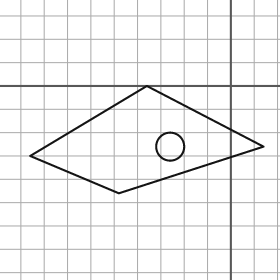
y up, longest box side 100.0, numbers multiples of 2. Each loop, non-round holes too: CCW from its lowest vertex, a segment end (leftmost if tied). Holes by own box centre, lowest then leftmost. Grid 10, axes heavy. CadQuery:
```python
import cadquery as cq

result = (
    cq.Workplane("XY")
    .moveTo(-48.0, -46.0)
    .lineTo(14.0, -26.0)
    .lineTo(-36.0, 0.0)
    .lineTo(-86.0, -30.0)
    .close()
    .moveTo(-26.0, -26.0)
    .circle(6.0)
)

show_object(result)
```